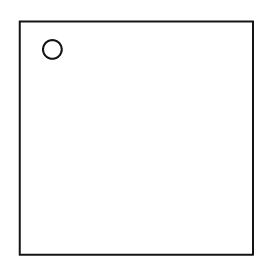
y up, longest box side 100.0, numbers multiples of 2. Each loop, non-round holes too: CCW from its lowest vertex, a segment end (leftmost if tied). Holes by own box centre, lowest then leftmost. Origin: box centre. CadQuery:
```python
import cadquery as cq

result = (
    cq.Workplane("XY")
    .moveTo(-50.0, -50.0)
    .lineTo(50.0, -50.0)
    .lineTo(50.0, 50.0)
    .lineTo(-50.0, 50.0)
    .close()
    .moveTo(-36.0, 38.0)
    .circle(4.0)
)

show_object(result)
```